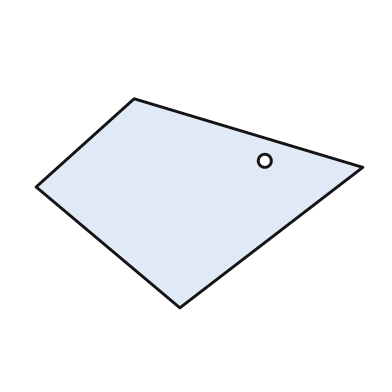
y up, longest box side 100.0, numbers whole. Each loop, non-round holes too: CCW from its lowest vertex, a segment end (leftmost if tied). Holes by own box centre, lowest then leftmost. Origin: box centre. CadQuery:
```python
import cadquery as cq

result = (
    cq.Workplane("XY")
    .moveTo(-6.0, -32.0)
    .lineTo(50.0, 11.0)
    .lineTo(-20.0, 32.0)
    .lineTo(-50.0, 5.0)
    .close()
    .moveTo(20.0, 13.0)
    .circle(2.0)
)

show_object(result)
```